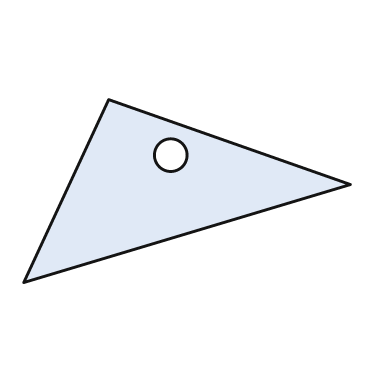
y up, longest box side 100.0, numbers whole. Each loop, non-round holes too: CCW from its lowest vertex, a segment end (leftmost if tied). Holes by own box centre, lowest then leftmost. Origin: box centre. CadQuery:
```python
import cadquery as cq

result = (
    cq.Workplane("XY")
    .moveTo(-50.0, -28.0)
    .lineTo(50.0, 2.0)
    .lineTo(-24.0, 28.0)
    .close()
    .moveTo(-5.0, 11.0)
    .circle(5.0)
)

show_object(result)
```